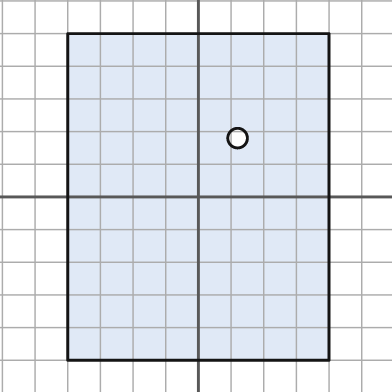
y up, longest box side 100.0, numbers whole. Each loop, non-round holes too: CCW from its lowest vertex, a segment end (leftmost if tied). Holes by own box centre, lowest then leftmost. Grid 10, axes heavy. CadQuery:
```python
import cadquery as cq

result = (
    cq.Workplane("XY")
    .moveTo(-40.0, -50.0)
    .lineTo(40.0, -50.0)
    .lineTo(40.0, 50.0)
    .lineTo(-40.0, 50.0)
    .close()
    .moveTo(12.0, 18.0)
    .circle(3.0)
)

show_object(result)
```